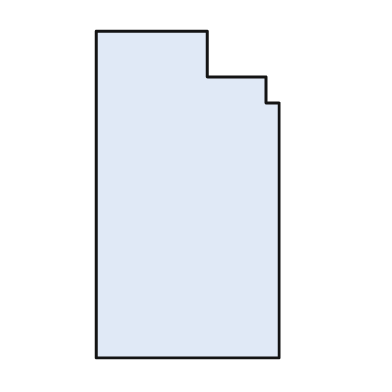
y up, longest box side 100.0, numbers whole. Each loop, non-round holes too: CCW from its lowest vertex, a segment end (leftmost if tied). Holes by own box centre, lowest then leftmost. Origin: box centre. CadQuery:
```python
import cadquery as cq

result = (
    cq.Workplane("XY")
    .moveTo(-28.0, -50.0)
    .lineTo(28.0, -50.0)
    .lineTo(28.0, 28.0)
    .lineTo(24.0, 28.0)
    .lineTo(24.0, 36.0)
    .lineTo(6.0, 36.0)
    .lineTo(6.0, 50.0)
    .lineTo(-28.0, 50.0)
    .close()
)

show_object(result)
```